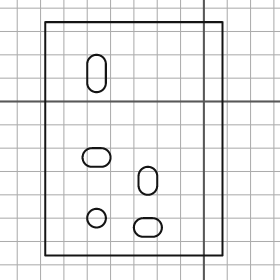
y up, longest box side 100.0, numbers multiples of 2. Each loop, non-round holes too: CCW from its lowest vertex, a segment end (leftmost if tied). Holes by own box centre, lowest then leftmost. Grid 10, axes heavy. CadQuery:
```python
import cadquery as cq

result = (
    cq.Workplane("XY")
    .moveTo(-68.0, -66.0)
    .lineTo(8.0, -66.0)
    .lineTo(8.0, 34.0)
    .lineTo(-68.0, 34.0)
    .close()
    .moveTo(-26.0, -58.0)
    .lineTo(-22.0, -58.0)
    .threePointArc((-18.0, -54.0), (-22.0, -50.0))
    .lineTo(-26.0, -50.0)
    .threePointArc((-30.0, -54.0), (-26.0, -58.0))
    .close()
    .moveTo(-46.0, -50.0)
    .circle(4.0)
    .moveTo(-28.0, -36.0)
    .threePointArc((-24.0, -40.0), (-20.0, -36.0))
    .lineTo(-20.0, -32.0)
    .threePointArc((-24.0, -28.0), (-28.0, -32.0))
    .close()
    .moveTo(-48.0, -28.0)
    .lineTo(-44.0, -28.0)
    .threePointArc((-40.0, -24.0), (-44.0, -20.0))
    .lineTo(-48.0, -20.0)
    .threePointArc((-52.0, -24.0), (-48.0, -28.0))
    .close()
    .moveTo(-50.0, 8.0)
    .threePointArc((-46.0, 4.0), (-42.0, 8.0))
    .lineTo(-42.0, 16.0)
    .threePointArc((-46.0, 20.0), (-50.0, 16.0))
    .close()
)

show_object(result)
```